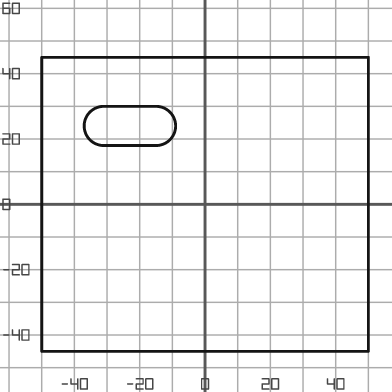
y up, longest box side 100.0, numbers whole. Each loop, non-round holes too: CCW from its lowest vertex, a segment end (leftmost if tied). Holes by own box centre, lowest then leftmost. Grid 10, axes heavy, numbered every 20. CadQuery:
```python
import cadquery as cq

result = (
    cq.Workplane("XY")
    .moveTo(-50.0, -45.0)
    .lineTo(50.0, -45.0)
    .lineTo(50.0, 45.0)
    .lineTo(-50.0, 45.0)
    .close()
    .moveTo(-31.0, 18.0)
    .lineTo(-15.0, 18.0)
    .threePointArc((-9.0, 24.0), (-15.0, 30.0))
    .lineTo(-31.0, 30.0)
    .threePointArc((-37.0, 24.0), (-31.0, 18.0))
    .close()
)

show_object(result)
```